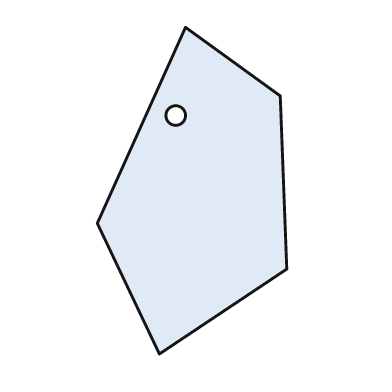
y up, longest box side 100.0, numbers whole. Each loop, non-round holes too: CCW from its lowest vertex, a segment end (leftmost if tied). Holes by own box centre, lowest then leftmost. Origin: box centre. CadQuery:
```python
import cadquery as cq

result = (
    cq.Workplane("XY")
    .moveTo(-10.0, -50.0)
    .lineTo(29.0, -24.0)
    .lineTo(27.0, 29.0)
    .lineTo(-2.0, 50.0)
    .lineTo(-29.0, -10.0)
    .close()
    .moveTo(-5.0, 23.0)
    .circle(3.0)
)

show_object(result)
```